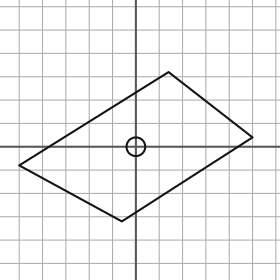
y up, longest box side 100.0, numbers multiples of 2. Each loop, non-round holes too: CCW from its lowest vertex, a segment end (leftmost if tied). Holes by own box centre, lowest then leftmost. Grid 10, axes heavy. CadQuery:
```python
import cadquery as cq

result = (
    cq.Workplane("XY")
    .moveTo(-6.0, -32.0)
    .lineTo(50.0, 4.0)
    .lineTo(14.0, 32.0)
    .lineTo(-50.0, -8.0)
    .close()
    .moveTo(0.0, 0.0)
    .circle(4.0)
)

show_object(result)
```